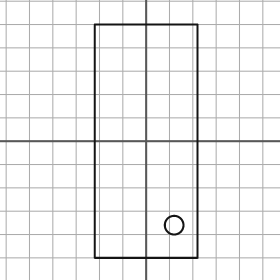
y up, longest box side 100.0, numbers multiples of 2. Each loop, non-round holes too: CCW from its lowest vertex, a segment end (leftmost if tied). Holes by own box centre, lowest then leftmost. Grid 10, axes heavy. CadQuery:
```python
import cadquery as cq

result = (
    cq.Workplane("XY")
    .moveTo(-22.0, -50.0)
    .lineTo(22.0, -50.0)
    .lineTo(22.0, 50.0)
    .lineTo(-22.0, 50.0)
    .close()
    .moveTo(12.0, -36.0)
    .circle(4.0)
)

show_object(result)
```